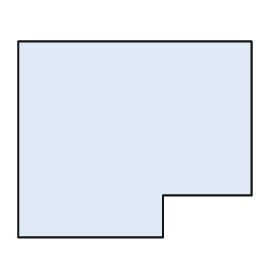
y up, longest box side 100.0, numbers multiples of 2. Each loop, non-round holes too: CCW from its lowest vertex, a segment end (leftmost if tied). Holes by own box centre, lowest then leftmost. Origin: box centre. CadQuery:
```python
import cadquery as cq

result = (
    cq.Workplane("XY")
    .moveTo(-50.0, -42.0)
    .lineTo(12.0, -42.0)
    .lineTo(12.0, -24.0)
    .lineTo(50.0, -24.0)
    .lineTo(50.0, 42.0)
    .lineTo(-50.0, 42.0)
    .close()
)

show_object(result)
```